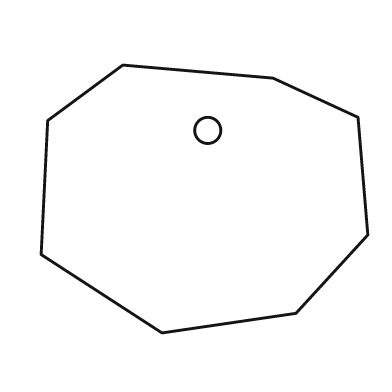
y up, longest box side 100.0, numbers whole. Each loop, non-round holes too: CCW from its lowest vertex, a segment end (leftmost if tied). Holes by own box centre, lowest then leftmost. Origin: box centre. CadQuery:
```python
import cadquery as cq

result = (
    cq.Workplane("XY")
    .moveTo(-13.0, -41.0)
    .lineTo(28.0, -35.0)
    .lineTo(50.0, -11.0)
    .lineTo(47.0, 25.0)
    .lineTo(21.0, 37.0)
    .lineTo(-25.0, 41.0)
    .lineTo(-48.0, 24.0)
    .lineTo(-50.0, -17.0)
    .close()
    .moveTo(1.0, 21.0)
    .circle(4.0)
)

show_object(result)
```